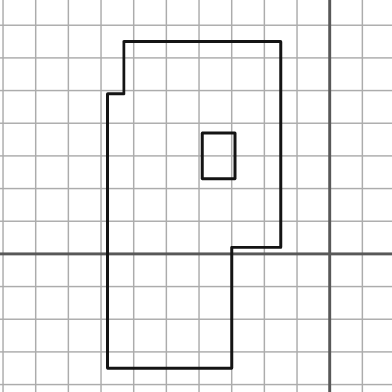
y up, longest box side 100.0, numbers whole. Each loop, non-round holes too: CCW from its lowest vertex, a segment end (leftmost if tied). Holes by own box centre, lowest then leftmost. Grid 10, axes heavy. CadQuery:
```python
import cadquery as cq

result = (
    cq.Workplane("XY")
    .moveTo(-68.0, -35.0)
    .lineTo(-30.0, -35.0)
    .lineTo(-30.0, 2.0)
    .lineTo(-15.0, 2.0)
    .lineTo(-15.0, 65.0)
    .lineTo(-63.0, 65.0)
    .lineTo(-63.0, 49.0)
    .lineTo(-68.0, 49.0)
    .close()
    .moveTo(-39.0, 23.0)
    .lineTo(-29.0, 23.0)
    .lineTo(-29.0, 37.0)
    .lineTo(-39.0, 37.0)
    .close()
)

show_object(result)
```